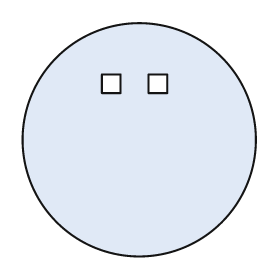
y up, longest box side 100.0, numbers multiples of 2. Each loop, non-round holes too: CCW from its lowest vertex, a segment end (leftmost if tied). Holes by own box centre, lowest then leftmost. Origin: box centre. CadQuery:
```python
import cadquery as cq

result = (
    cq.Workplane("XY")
    .moveTo(0.0, 0.0)
    .circle(50.0)
    .moveTo(-16.0, 20.0)
    .lineTo(-8.0, 20.0)
    .lineTo(-8.0, 28.0)
    .lineTo(-16.0, 28.0)
    .close()
    .moveTo(4.0, 20.0)
    .lineTo(12.0, 20.0)
    .lineTo(12.0, 28.0)
    .lineTo(4.0, 28.0)
    .close()
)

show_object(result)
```